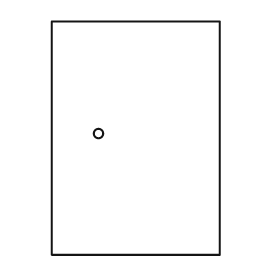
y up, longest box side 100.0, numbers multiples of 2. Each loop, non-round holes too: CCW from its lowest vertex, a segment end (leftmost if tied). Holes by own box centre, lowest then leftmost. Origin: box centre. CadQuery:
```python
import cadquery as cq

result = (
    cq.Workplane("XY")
    .moveTo(-36.0, -50.0)
    .lineTo(36.0, -50.0)
    .lineTo(36.0, 50.0)
    .lineTo(-36.0, 50.0)
    .close()
    .moveTo(-16.0, 2.0)
    .circle(2.0)
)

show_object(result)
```